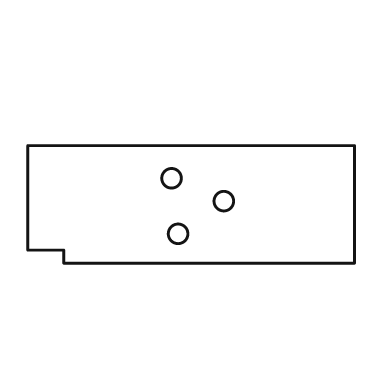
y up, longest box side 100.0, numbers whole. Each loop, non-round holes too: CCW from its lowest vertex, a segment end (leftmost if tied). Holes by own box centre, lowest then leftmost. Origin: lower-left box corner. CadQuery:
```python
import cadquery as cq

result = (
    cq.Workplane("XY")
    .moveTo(11.0, 0.0)
    .lineTo(100.0, 0.0)
    .lineTo(100.0, 36.0)
    .lineTo(0.0, 36.0)
    .lineTo(0.0, 4.0)
    .lineTo(11.0, 4.0)
    .close()
    .moveTo(46.0, 9.0)
    .circle(3.0)
    .moveTo(60.0, 19.0)
    .circle(3.0)
    .moveTo(44.0, 26.0)
    .circle(3.0)
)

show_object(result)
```